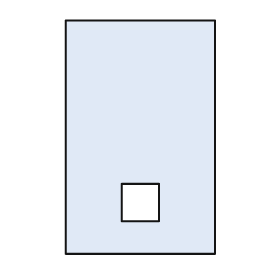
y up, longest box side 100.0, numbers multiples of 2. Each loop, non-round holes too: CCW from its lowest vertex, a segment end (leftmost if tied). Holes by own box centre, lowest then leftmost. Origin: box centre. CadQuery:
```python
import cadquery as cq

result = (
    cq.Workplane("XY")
    .moveTo(-32.0, -50.0)
    .lineTo(32.0, -50.0)
    .lineTo(32.0, 50.0)
    .lineTo(-32.0, 50.0)
    .close()
    .moveTo(-8.0, -36.0)
    .lineTo(8.0, -36.0)
    .lineTo(8.0, -20.0)
    .lineTo(-8.0, -20.0)
    .close()
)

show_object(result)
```